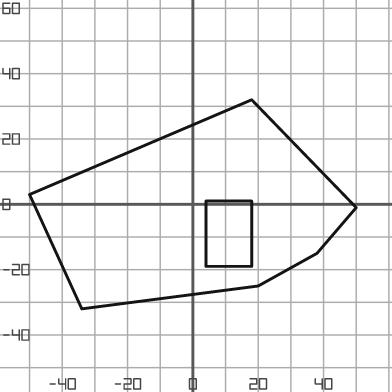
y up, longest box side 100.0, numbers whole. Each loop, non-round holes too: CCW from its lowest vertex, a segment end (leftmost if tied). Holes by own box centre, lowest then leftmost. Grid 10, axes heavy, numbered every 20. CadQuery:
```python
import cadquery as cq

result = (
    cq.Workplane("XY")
    .moveTo(-34.0, -32.0)
    .lineTo(20.0, -25.0)
    .lineTo(38.0, -15.0)
    .lineTo(50.0, -1.0)
    .lineTo(18.0, 32.0)
    .lineTo(-50.0, 3.0)
    .close()
    .moveTo(4.0, -19.0)
    .lineTo(18.0, -19.0)
    .lineTo(18.0, 1.0)
    .lineTo(4.0, 1.0)
    .close()
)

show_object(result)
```